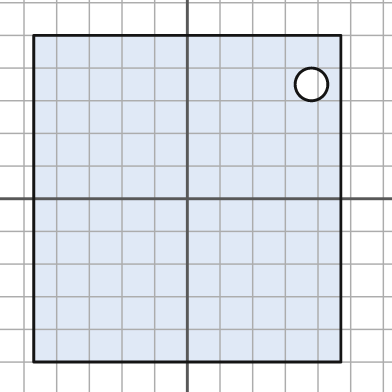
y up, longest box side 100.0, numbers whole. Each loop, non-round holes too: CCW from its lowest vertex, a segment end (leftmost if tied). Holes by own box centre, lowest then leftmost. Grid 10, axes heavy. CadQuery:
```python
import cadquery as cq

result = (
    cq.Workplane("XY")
    .moveTo(-47.0, -50.0)
    .lineTo(47.0, -50.0)
    .lineTo(47.0, 50.0)
    .lineTo(-47.0, 50.0)
    .close()
    .moveTo(38.0, 35.0)
    .circle(5.0)
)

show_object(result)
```